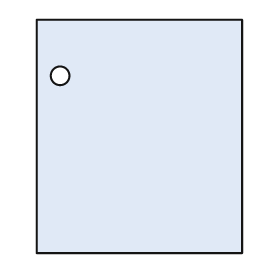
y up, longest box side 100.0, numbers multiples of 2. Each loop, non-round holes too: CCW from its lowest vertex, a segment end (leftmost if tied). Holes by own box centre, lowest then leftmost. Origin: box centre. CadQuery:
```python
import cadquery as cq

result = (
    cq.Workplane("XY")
    .moveTo(-44.0, -50.0)
    .lineTo(44.0, -50.0)
    .lineTo(44.0, 50.0)
    .lineTo(-44.0, 50.0)
    .close()
    .moveTo(-34.0, 26.0)
    .circle(4.0)
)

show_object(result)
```